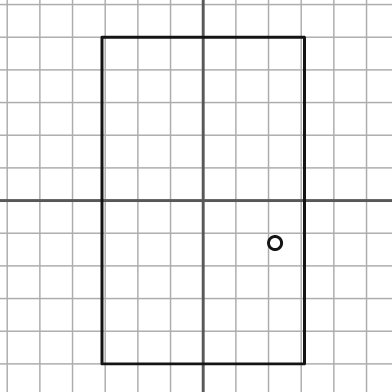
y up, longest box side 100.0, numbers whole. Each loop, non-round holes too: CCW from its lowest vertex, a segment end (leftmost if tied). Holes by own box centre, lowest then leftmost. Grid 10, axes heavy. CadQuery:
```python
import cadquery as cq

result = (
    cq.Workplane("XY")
    .moveTo(-31.0, -50.0)
    .lineTo(31.0, -50.0)
    .lineTo(31.0, 50.0)
    .lineTo(-31.0, 50.0)
    .close()
    .moveTo(22.0, -13.0)
    .circle(2.0)
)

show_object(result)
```